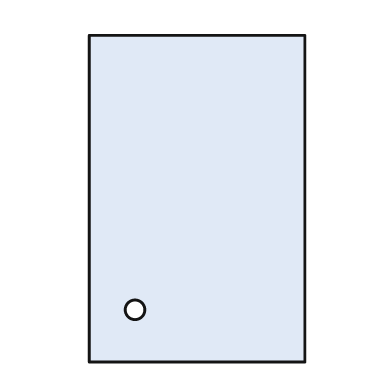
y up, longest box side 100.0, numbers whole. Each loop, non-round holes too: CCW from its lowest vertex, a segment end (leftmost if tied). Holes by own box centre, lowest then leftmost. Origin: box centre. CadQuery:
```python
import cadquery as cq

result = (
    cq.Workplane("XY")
    .moveTo(-33.0, -50.0)
    .lineTo(33.0, -50.0)
    .lineTo(33.0, 50.0)
    .lineTo(-33.0, 50.0)
    .close()
    .moveTo(-19.0, -34.0)
    .circle(3.0)
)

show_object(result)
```